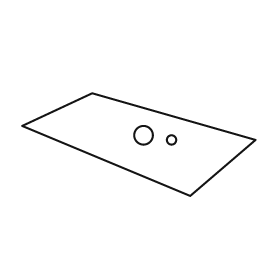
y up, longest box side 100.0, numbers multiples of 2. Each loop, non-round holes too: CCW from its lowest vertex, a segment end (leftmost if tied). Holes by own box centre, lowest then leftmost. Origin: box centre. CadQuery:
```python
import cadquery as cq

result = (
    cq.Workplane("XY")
    .moveTo(22.0, -22.0)
    .lineTo(50.0, 2.0)
    .lineTo(-20.0, 22.0)
    .lineTo(-50.0, 8.0)
    .close()
    .moveTo(14.0, 2.0)
    .circle(2.0)
    .moveTo(2.0, 4.0)
    .circle(4.0)
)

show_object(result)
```